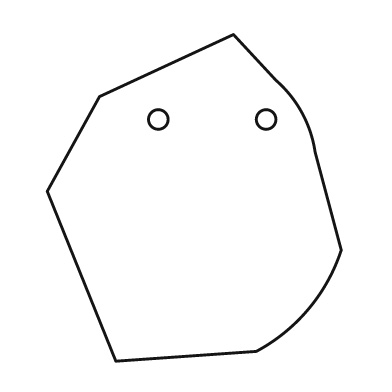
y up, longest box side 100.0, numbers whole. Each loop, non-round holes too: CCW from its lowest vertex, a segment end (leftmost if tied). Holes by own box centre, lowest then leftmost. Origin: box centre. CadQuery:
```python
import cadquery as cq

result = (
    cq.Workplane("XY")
    .moveTo(-24.0, -50.0)
    .lineTo(19.0, -47.0)
    .threePointArc((35.0, -34.0), (45.0, -16.0))
    .lineTo(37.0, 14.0)
    .threePointArc((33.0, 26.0), (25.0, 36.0))
    .lineTo(12.0, 50.0)
    .lineTo(-29.0, 31.0)
    .lineTo(-45.0, 2.0)
    .close()
    .moveTo(-11.0, 24.0)
    .circle(3.0)
    .moveTo(22.0, 24.0)
    .circle(3.0)
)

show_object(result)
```